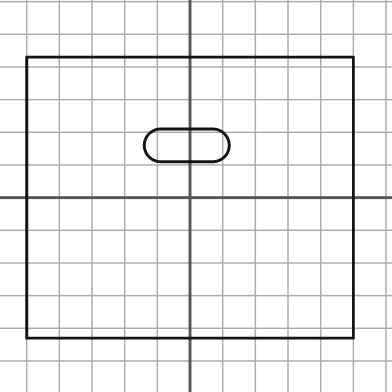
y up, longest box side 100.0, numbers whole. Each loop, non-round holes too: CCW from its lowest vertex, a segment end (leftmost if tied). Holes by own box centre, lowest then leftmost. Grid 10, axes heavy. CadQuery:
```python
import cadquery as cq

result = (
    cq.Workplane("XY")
    .moveTo(-50.0, -43.0)
    .lineTo(50.0, -43.0)
    .lineTo(50.0, 43.0)
    .lineTo(-50.0, 43.0)
    .close()
    .moveTo(-9.0, 11.0)
    .lineTo(7.0, 11.0)
    .threePointArc((12.0, 16.0), (7.0, 21.0))
    .lineTo(-9.0, 21.0)
    .threePointArc((-14.0, 16.0), (-9.0, 11.0))
    .close()
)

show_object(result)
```